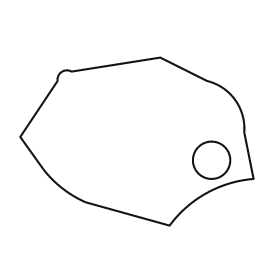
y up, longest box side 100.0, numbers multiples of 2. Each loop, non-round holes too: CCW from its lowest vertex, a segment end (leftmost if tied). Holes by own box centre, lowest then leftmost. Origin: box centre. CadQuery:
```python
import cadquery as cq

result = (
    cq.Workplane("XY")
    .moveTo(14.0, -36.0)
    .threePointArc((30.0, -22.0), (50.0, -16.0))
    .lineTo(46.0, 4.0)
    .threePointArc((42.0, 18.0), (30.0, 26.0))
    .lineTo(10.0, 36.0)
    .lineTo(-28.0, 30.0)
    .threePointArc((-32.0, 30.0), (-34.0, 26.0))
    .lineTo(-50.0, 2.0)
    .lineTo(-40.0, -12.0)
    .threePointArc((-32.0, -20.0), (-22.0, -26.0))
    .close()
    .moveTo(32.0, -8.0)
    .circle(8.0)
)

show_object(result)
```